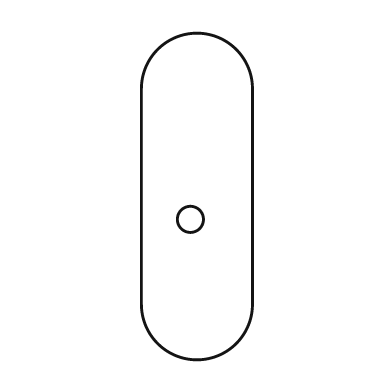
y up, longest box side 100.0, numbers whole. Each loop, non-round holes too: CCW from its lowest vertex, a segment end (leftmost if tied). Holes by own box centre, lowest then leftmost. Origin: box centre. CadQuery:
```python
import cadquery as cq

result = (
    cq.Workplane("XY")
    .moveTo(-17.0, -33.0)
    .threePointArc((0.0, -50.0), (17.0, -33.0))
    .lineTo(17.0, 33.0)
    .threePointArc((0.0, 50.0), (-17.0, 33.0))
    .close()
    .moveTo(-2.0, -7.0)
    .circle(4.0)
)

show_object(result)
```